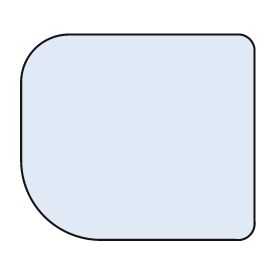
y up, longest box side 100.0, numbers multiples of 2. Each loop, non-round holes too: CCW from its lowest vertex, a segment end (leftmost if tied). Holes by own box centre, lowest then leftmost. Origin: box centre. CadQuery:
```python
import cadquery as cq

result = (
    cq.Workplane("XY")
    .moveTo(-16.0, -44.0)
    .lineTo(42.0, -44.0)
    .threePointArc((48.0, -42.0), (50.0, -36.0))
    .lineTo(50.0, 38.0)
    .threePointArc((48.0, 42.0), (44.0, 44.0))
    .lineTo(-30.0, 44.0)
    .threePointArc((-44.0, 38.0), (-50.0, 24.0))
    .lineTo(-50.0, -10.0)
    .threePointArc((-40.0, -34.0), (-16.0, -44.0))
    .close()
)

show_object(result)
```